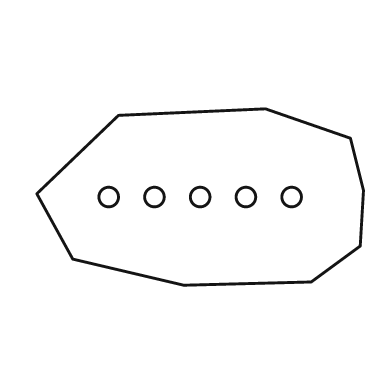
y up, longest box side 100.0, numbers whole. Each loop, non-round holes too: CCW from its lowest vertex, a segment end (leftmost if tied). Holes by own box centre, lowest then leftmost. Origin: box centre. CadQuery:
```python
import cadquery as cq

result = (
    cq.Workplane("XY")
    .moveTo(-5.0, -27.0)
    .lineTo(34.0, -26.0)
    .lineTo(49.0, -15.0)
    .lineTo(50.0, 2.0)
    .lineTo(46.0, 18.0)
    .lineTo(20.0, 27.0)
    .lineTo(-25.0, 25.0)
    .lineTo(-50.0, 1.0)
    .lineTo(-39.0, -19.0)
    .close()
    .moveTo(-28.0, 0.0)
    .circle(3.0)
    .moveTo(-14.0, 0.0)
    .circle(3.0)
    .moveTo(0.0, 0.0)
    .circle(3.0)
    .moveTo(14.0, 0.0)
    .circle(3.0)
    .moveTo(28.0, 0.0)
    .circle(3.0)
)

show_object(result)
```